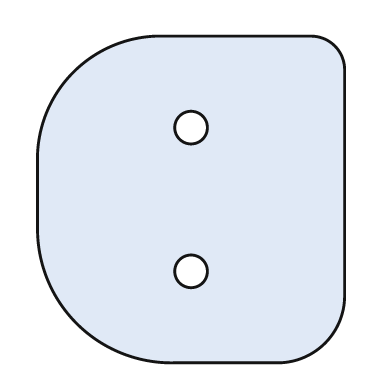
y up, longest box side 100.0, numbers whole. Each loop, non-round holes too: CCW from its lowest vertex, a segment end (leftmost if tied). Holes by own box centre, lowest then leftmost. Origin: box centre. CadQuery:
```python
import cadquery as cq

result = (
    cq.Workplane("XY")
    .moveTo(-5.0, -50.0)
    .lineTo(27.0, -50.0)
    .threePointArc((41.0, -44.0), (47.0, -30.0))
    .lineTo(47.0, 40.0)
    .threePointArc((44.0, 47.0), (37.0, 50.0))
    .lineTo(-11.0, 50.0)
    .threePointArc((-36.0, 39.0), (-47.0, 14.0))
    .lineTo(-47.0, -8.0)
    .threePointArc((-35.0, -38.0), (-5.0, -50.0))
    .close()
    .moveTo(0.0, -22.0)
    .circle(5.0)
    .moveTo(0.0, 22.0)
    .circle(5.0)
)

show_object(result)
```